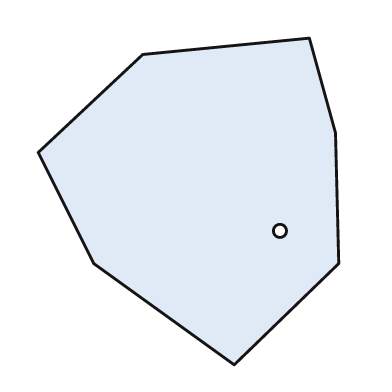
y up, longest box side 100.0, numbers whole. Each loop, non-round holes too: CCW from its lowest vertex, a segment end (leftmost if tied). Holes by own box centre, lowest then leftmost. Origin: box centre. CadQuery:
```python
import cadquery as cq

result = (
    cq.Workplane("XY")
    .moveTo(14.0, -50.0)
    .lineTo(46.0, -19.0)
    .lineTo(45.0, 21.0)
    .lineTo(37.0, 50.0)
    .lineTo(-14.0, 45.0)
    .lineTo(-46.0, 15.0)
    .lineTo(-29.0, -19.0)
    .close()
    .moveTo(28.0, -9.0)
    .circle(2.0)
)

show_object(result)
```